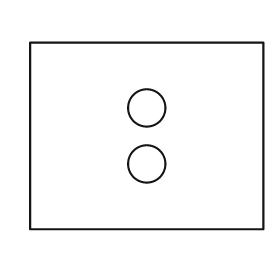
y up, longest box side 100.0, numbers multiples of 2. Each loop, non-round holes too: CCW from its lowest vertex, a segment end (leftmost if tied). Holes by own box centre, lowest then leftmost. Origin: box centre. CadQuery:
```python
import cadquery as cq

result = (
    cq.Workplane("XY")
    .moveTo(-50.0, -40.0)
    .lineTo(50.0, -40.0)
    .lineTo(50.0, 40.0)
    .lineTo(-50.0, 40.0)
    .close()
    .moveTo(0.0, -12.0)
    .circle(8.0)
    .moveTo(0.0, 12.0)
    .circle(8.0)
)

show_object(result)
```